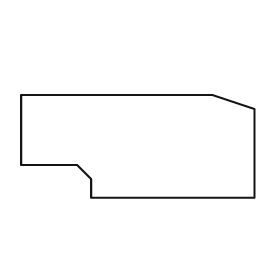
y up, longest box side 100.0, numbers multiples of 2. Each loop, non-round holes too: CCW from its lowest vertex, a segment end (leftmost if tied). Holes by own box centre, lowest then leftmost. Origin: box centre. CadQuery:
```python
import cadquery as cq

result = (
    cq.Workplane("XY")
    .moveTo(-20.0, -22.0)
    .lineTo(50.0, -22.0)
    .lineTo(50.0, 16.0)
    .lineTo(32.0, 22.0)
    .lineTo(-50.0, 22.0)
    .lineTo(-50.0, -8.0)
    .lineTo(-26.0, -8.0)
    .lineTo(-20.0, -14.0)
    .close()
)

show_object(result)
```